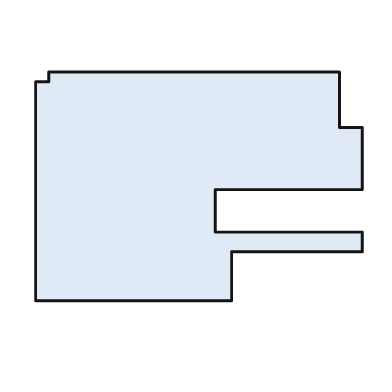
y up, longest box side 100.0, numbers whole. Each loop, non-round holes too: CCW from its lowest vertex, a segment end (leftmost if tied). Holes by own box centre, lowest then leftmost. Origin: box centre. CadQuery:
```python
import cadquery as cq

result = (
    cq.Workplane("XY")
    .moveTo(-50.0, -35.0)
    .lineTo(10.0, -35.0)
    .lineTo(10.0, -20.0)
    .lineTo(50.0, -20.0)
    .lineTo(50.0, -14.0)
    .lineTo(5.0, -14.0)
    .lineTo(5.0, -1.0)
    .lineTo(50.0, -1.0)
    .lineTo(50.0, 18.0)
    .lineTo(43.0, 18.0)
    .lineTo(43.0, 35.0)
    .lineTo(-46.0, 35.0)
    .lineTo(-46.0, 32.0)
    .lineTo(-50.0, 32.0)
    .close()
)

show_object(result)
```